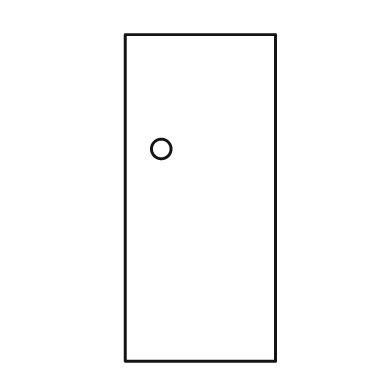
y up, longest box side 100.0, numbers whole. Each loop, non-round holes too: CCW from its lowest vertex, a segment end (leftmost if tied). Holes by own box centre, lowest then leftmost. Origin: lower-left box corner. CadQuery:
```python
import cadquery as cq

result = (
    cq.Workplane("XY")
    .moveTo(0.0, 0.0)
    .lineTo(46.0, 0.0)
    .lineTo(46.0, 100.0)
    .lineTo(0.0, 100.0)
    .close()
    .moveTo(11.0, 65.0)
    .circle(3.0)
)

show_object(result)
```